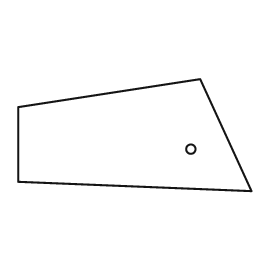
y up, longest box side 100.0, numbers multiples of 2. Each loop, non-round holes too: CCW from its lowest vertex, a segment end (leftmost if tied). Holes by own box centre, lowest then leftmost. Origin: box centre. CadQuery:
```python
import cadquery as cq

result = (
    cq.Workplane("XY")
    .moveTo(50.0, -24.0)
    .lineTo(28.0, 24.0)
    .lineTo(-50.0, 12.0)
    .lineTo(-50.0, -20.0)
    .close()
    .moveTo(24.0, -6.0)
    .circle(2.0)
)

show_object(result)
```